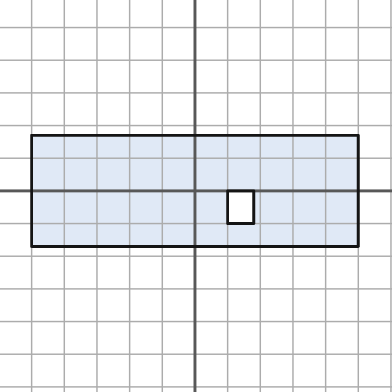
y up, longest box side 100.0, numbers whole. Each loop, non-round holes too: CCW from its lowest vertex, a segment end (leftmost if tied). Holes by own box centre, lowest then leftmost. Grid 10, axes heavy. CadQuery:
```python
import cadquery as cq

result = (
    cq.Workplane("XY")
    .moveTo(-50.0, -17.0)
    .lineTo(50.0, -17.0)
    .lineTo(50.0, 17.0)
    .lineTo(-50.0, 17.0)
    .close()
    .moveTo(10.0, -10.0)
    .lineTo(18.0, -10.0)
    .lineTo(18.0, 0.0)
    .lineTo(10.0, 0.0)
    .close()
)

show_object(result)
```